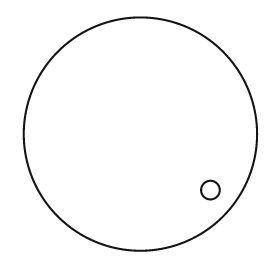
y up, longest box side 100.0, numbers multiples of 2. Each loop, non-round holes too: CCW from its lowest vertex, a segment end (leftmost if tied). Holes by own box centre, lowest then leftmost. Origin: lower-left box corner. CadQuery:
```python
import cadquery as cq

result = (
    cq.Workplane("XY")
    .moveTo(50.0, 50.0)
    .circle(50.0)
    .moveTo(80.0, 26.0)
    .circle(4.0)
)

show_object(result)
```